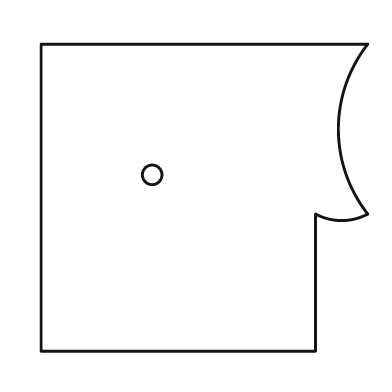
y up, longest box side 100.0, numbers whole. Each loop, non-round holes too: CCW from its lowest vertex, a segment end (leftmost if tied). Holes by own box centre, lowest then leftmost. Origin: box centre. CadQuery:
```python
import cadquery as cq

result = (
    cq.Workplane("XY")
    .moveTo(-50.0, -47.0)
    .lineTo(34.0, -47.0)
    .lineTo(34.0, -5.0)
    .threePointArc((42.0, -7.0), (50.0, -5.0))
    .threePointArc((41.0, 21.0), (50.0, 47.0))
    .lineTo(-50.0, 47.0)
    .close()
    .moveTo(-16.0, 7.0)
    .circle(3.0)
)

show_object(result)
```